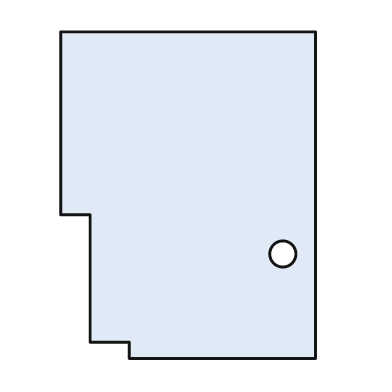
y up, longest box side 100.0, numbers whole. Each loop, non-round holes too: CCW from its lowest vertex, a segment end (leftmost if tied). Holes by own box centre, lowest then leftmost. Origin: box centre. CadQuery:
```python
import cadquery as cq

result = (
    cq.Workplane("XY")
    .moveTo(-18.0, -50.0)
    .lineTo(39.0, -50.0)
    .lineTo(39.0, 50.0)
    .lineTo(-39.0, 50.0)
    .lineTo(-39.0, -6.0)
    .lineTo(-30.0, -6.0)
    .lineTo(-30.0, -45.0)
    .lineTo(-18.0, -45.0)
    .close()
    .moveTo(29.0, -18.0)
    .circle(4.0)
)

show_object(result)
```